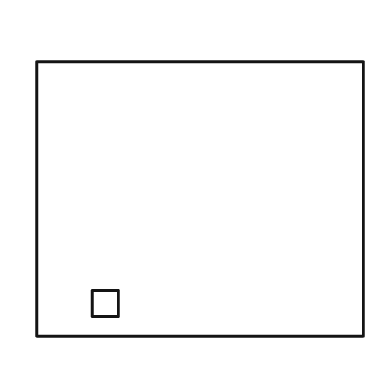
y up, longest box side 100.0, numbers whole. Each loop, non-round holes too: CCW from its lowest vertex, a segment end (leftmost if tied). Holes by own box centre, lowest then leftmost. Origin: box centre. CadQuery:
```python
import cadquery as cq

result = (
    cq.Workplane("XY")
    .moveTo(-50.0, -42.0)
    .lineTo(50.0, -42.0)
    .lineTo(50.0, 42.0)
    .lineTo(-50.0, 42.0)
    .close()
    .moveTo(-33.0, -36.0)
    .lineTo(-25.0, -36.0)
    .lineTo(-25.0, -28.0)
    .lineTo(-33.0, -28.0)
    .close()
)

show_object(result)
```